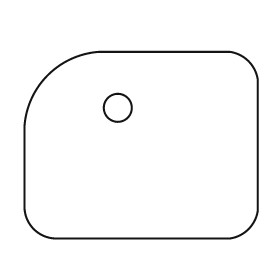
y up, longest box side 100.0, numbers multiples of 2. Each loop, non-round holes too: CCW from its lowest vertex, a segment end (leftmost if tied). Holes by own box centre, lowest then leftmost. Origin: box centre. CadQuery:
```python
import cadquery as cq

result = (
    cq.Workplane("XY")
    .moveTo(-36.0, -40.0)
    .lineTo(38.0, -40.0)
    .threePointArc((46.0, -36.0), (50.0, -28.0))
    .lineTo(50.0, 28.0)
    .threePointArc((46.0, 36.0), (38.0, 40.0))
    .lineTo(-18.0, 40.0)
    .threePointArc((-40.0, 30.0), (-50.0, 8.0))
    .lineTo(-50.0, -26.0)
    .threePointArc((-46.0, -36.0), (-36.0, -40.0))
    .close()
    .moveTo(-10.0, 16.0)
    .circle(6.0)
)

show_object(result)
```